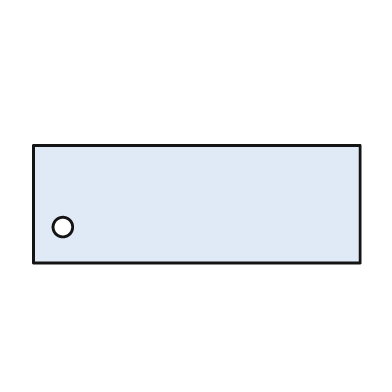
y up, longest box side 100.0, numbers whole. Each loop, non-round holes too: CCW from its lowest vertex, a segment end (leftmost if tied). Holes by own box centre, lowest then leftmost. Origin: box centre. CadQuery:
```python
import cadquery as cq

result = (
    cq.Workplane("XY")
    .moveTo(-50.0, -18.0)
    .lineTo(50.0, -18.0)
    .lineTo(50.0, 18.0)
    .lineTo(-50.0, 18.0)
    .close()
    .moveTo(-41.0, -7.0)
    .circle(3.0)
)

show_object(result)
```